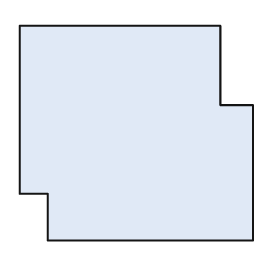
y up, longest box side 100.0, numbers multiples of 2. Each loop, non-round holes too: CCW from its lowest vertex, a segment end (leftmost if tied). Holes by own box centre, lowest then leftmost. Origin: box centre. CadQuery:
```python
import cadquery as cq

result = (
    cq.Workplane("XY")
    .moveTo(-38.0, -46.0)
    .lineTo(50.0, -46.0)
    .lineTo(50.0, 12.0)
    .lineTo(36.0, 12.0)
    .lineTo(36.0, 46.0)
    .lineTo(-50.0, 46.0)
    .lineTo(-50.0, -26.0)
    .lineTo(-38.0, -26.0)
    .close()
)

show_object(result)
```